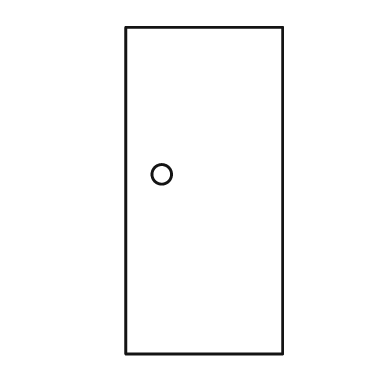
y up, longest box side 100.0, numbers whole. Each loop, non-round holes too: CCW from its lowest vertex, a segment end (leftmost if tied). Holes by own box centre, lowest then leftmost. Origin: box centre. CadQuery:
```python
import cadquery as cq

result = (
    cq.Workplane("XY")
    .moveTo(-24.0, -50.0)
    .lineTo(24.0, -50.0)
    .lineTo(24.0, 50.0)
    .lineTo(-24.0, 50.0)
    .close()
    .moveTo(-13.0, 5.0)
    .circle(3.0)
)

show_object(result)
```